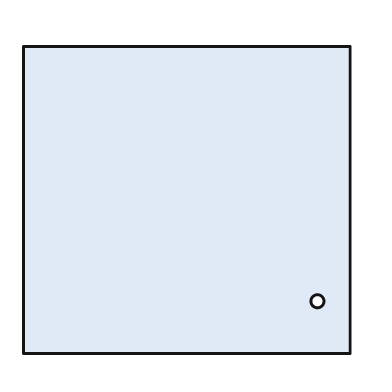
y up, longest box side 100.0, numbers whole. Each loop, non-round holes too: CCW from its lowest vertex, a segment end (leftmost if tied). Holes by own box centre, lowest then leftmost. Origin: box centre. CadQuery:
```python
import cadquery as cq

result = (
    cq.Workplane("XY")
    .moveTo(-50.0, -47.0)
    .lineTo(50.0, -47.0)
    .lineTo(50.0, 47.0)
    .lineTo(-50.0, 47.0)
    .close()
    .moveTo(40.0, -31.0)
    .circle(2.0)
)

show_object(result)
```